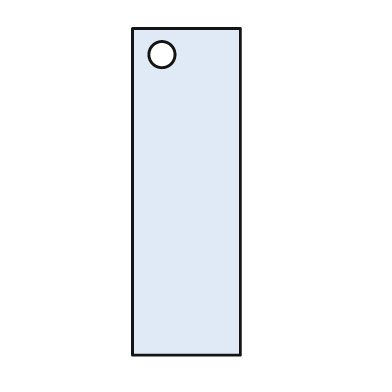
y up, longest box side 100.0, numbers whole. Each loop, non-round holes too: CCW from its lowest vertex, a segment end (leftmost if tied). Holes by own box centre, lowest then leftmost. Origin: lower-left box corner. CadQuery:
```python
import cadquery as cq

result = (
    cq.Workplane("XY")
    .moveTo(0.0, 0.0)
    .lineTo(33.0, 0.0)
    .lineTo(33.0, 100.0)
    .lineTo(0.0, 100.0)
    .close()
    .moveTo(9.0, 92.0)
    .circle(4.0)
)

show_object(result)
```